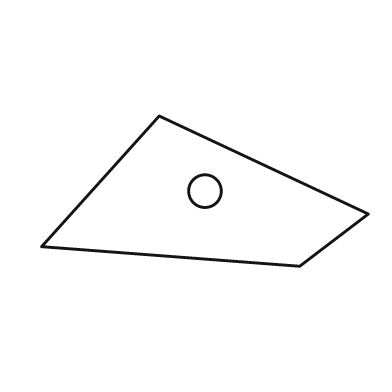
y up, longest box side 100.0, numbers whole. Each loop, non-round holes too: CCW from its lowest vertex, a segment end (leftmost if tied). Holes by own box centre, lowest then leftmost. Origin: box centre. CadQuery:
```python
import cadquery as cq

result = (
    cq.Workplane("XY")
    .moveTo(29.0, -23.0)
    .lineTo(50.0, -7.0)
    .lineTo(-14.0, 23.0)
    .lineTo(-50.0, -17.0)
    .close()
    .moveTo(0.0, 0.0)
    .circle(5.0)
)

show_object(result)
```